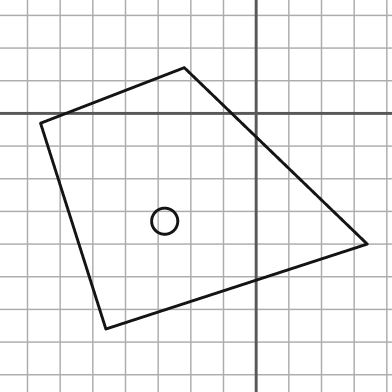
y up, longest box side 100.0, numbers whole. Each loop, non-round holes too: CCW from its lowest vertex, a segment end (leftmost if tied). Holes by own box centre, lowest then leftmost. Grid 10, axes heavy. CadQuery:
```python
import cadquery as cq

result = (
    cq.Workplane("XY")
    .moveTo(-46.0, -66.0)
    .lineTo(34.0, -40.0)
    .lineTo(-22.0, 14.0)
    .lineTo(-66.0, -3.0)
    .close()
    .moveTo(-28.0, -33.0)
    .circle(4.0)
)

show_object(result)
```